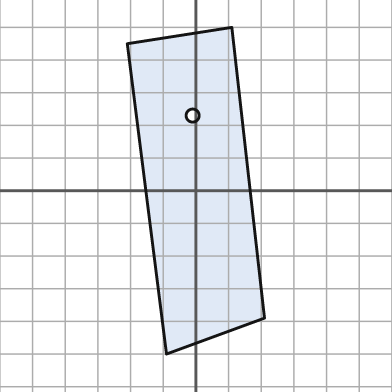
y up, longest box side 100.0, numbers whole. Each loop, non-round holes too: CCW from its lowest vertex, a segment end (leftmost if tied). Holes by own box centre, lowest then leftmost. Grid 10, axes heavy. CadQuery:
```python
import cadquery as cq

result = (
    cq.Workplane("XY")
    .moveTo(-9.0, -50.0)
    .lineTo(21.0, -39.0)
    .lineTo(11.0, 50.0)
    .lineTo(-21.0, 45.0)
    .close()
    .moveTo(-1.0, 23.0)
    .circle(2.0)
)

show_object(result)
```